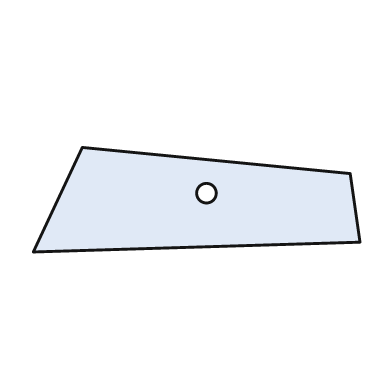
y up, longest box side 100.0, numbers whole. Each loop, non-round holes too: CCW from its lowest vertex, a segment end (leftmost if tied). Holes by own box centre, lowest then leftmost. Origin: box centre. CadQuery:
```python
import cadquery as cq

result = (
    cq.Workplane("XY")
    .moveTo(-50.0, -16.0)
    .lineTo(50.0, -13.0)
    .lineTo(47.0, 8.0)
    .lineTo(-35.0, 16.0)
    .close()
    .moveTo(3.0, 2.0)
    .circle(3.0)
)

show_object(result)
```